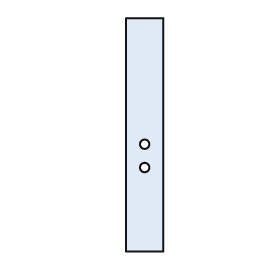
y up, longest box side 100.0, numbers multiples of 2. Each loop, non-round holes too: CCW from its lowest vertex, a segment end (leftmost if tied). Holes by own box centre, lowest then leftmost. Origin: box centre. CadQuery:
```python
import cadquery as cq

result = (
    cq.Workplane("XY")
    .moveTo(-8.0, -50.0)
    .lineTo(8.0, -50.0)
    .lineTo(8.0, 50.0)
    .lineTo(-8.0, 50.0)
    .close()
    .moveTo(0.0, -14.0)
    .circle(2.0)
    .moveTo(0.0, -4.0)
    .circle(2.0)
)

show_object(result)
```